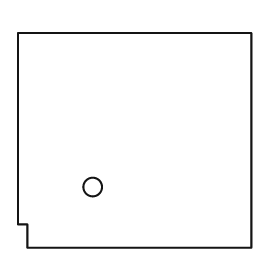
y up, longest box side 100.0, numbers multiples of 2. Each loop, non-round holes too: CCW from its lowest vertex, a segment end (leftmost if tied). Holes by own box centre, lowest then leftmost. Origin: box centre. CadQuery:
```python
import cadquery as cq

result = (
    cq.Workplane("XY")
    .moveTo(-46.0, -46.0)
    .lineTo(50.0, -46.0)
    .lineTo(50.0, 46.0)
    .lineTo(-50.0, 46.0)
    .lineTo(-50.0, -36.0)
    .lineTo(-46.0, -36.0)
    .close()
    .moveTo(-18.0, -20.0)
    .circle(4.0)
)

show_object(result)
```